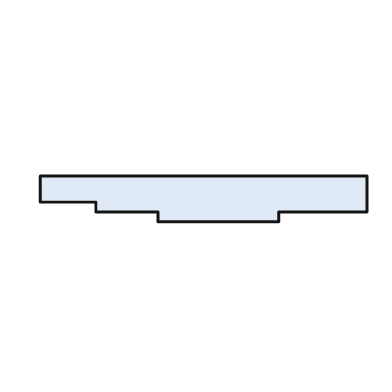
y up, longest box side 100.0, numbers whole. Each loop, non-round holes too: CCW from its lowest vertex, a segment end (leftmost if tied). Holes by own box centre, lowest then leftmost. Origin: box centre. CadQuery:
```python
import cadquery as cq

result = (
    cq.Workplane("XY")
    .moveTo(-14.0, -7.0)
    .lineTo(23.0, -7.0)
    .lineTo(23.0, -4.0)
    .lineTo(50.0, -4.0)
    .lineTo(50.0, 7.0)
    .lineTo(-50.0, 7.0)
    .lineTo(-50.0, -1.0)
    .lineTo(-33.0, -1.0)
    .lineTo(-33.0, -4.0)
    .lineTo(-14.0, -4.0)
    .close()
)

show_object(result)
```